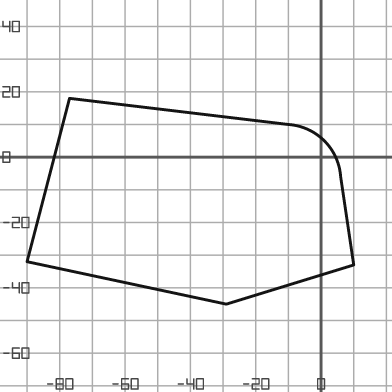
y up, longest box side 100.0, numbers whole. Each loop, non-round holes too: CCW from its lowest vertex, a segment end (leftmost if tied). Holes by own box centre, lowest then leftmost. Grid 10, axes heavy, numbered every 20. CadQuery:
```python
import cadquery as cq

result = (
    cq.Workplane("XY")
    .moveTo(-29.0, -45.0)
    .lineTo(10.0, -33.0)
    .lineTo(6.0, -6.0)
    .threePointArc((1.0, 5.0), (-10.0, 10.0))
    .lineTo(-77.0, 18.0)
    .lineTo(-90.0, -32.0)
    .close()
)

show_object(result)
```